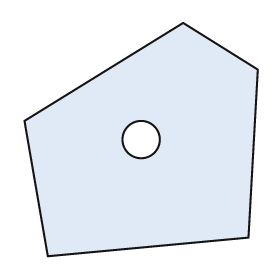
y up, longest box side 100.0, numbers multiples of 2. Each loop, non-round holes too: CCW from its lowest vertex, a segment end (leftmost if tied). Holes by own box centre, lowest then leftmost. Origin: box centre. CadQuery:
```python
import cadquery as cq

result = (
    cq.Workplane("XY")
    .moveTo(-40.0, -50.0)
    .lineTo(46.0, -42.0)
    .lineTo(50.0, 30.0)
    .lineTo(18.0, 50.0)
    .lineTo(-50.0, 8.0)
    .close()
    .moveTo(0.0, 0.0)
    .circle(8.0)
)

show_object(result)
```